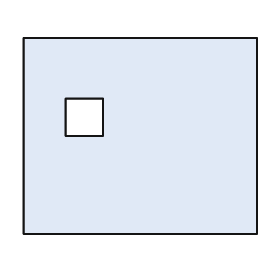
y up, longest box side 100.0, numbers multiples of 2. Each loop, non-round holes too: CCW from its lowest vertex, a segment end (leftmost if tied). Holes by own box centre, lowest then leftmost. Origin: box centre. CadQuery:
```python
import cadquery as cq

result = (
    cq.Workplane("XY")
    .moveTo(-50.0, -42.0)
    .lineTo(50.0, -42.0)
    .lineTo(50.0, 42.0)
    .lineTo(-50.0, 42.0)
    .close()
    .moveTo(-32.0, 0.0)
    .lineTo(-16.0, 0.0)
    .lineTo(-16.0, 16.0)
    .lineTo(-32.0, 16.0)
    .close()
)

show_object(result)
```